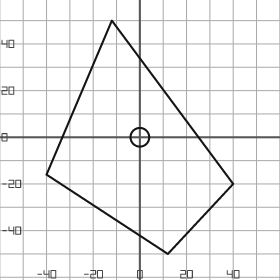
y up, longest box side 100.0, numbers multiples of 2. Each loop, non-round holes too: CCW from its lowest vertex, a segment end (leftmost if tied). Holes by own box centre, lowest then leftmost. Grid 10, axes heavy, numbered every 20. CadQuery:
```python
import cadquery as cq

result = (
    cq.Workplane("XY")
    .moveTo(12.0, -50.0)
    .lineTo(40.0, -20.0)
    .lineTo(-12.0, 50.0)
    .lineTo(-40.0, -16.0)
    .close()
    .moveTo(0.0, 0.0)
    .circle(4.0)
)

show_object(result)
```